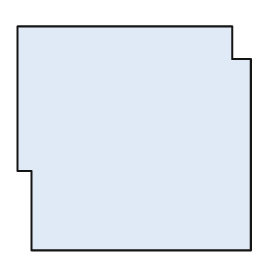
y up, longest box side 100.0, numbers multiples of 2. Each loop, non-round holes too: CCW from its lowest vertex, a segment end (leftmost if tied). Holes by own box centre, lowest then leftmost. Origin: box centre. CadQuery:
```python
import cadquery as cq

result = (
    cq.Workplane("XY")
    .moveTo(-44.0, -48.0)
    .lineTo(50.0, -48.0)
    .lineTo(50.0, 34.0)
    .lineTo(42.0, 34.0)
    .lineTo(42.0, 48.0)
    .lineTo(-50.0, 48.0)
    .lineTo(-50.0, -14.0)
    .lineTo(-44.0, -14.0)
    .close()
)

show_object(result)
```